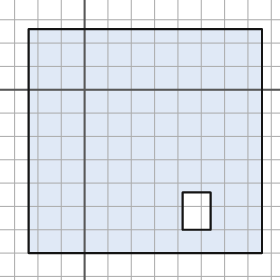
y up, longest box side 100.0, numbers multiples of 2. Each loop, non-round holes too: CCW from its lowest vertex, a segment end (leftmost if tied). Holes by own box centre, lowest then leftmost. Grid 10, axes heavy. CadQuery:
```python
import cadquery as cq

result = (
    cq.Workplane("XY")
    .moveTo(-24.0, -70.0)
    .lineTo(76.0, -70.0)
    .lineTo(76.0, 26.0)
    .lineTo(-24.0, 26.0)
    .close()
    .moveTo(42.0, -60.0)
    .lineTo(54.0, -60.0)
    .lineTo(54.0, -44.0)
    .lineTo(42.0, -44.0)
    .close()
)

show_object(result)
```